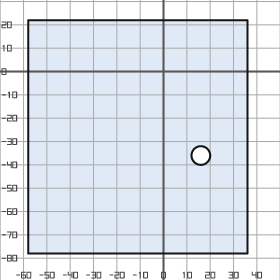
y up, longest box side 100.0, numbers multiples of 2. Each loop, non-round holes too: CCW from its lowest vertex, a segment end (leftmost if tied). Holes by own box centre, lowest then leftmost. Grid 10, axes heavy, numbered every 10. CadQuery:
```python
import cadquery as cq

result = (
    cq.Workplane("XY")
    .moveTo(-58.0, -78.0)
    .lineTo(36.0, -78.0)
    .lineTo(36.0, 22.0)
    .lineTo(-58.0, 22.0)
    .close()
    .moveTo(16.0, -36.0)
    .circle(4.0)
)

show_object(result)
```